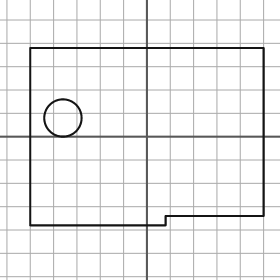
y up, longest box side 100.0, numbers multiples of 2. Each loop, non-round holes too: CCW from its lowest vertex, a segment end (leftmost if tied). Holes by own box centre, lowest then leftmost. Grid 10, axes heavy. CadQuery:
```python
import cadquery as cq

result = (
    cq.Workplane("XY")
    .moveTo(-50.0, -38.0)
    .lineTo(8.0, -38.0)
    .lineTo(8.0, -34.0)
    .lineTo(50.0, -34.0)
    .lineTo(50.0, 38.0)
    .lineTo(-50.0, 38.0)
    .close()
    .moveTo(-36.0, 8.0)
    .circle(8.0)
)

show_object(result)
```